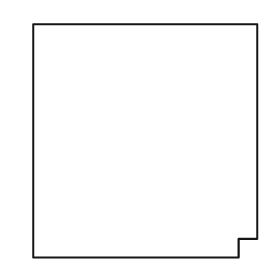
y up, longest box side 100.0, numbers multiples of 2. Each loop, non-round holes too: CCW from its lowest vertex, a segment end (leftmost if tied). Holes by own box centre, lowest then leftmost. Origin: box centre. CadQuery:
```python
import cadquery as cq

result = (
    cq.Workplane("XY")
    .moveTo(-48.0, -50.0)
    .lineTo(40.0, -50.0)
    .lineTo(40.0, -42.0)
    .lineTo(48.0, -42.0)
    .lineTo(48.0, 50.0)
    .lineTo(-48.0, 50.0)
    .close()
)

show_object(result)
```